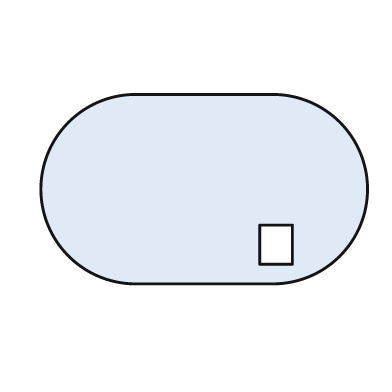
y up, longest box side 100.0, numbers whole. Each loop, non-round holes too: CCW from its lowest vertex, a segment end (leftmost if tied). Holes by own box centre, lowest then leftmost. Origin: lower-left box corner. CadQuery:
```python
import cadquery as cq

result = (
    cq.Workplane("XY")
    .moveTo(29.0, 0.0)
    .lineTo(71.0, 0.0)
    .threePointArc((100.0, 29.0), (71.0, 58.0))
    .lineTo(29.0, 58.0)
    .threePointArc((0.0, 29.0), (29.0, 0.0))
    .close()
    .moveTo(67.0, 6.0)
    .lineTo(77.0, 6.0)
    .lineTo(77.0, 18.0)
    .lineTo(67.0, 18.0)
    .close()
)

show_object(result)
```